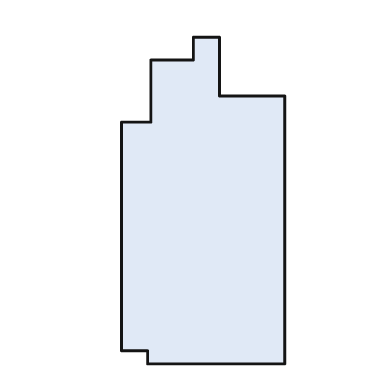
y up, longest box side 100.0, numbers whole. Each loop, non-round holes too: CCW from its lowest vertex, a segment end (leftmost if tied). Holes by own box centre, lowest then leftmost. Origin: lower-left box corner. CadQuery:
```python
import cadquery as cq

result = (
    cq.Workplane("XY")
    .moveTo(8.0, 0.0)
    .lineTo(50.0, 0.0)
    .lineTo(50.0, 82.0)
    .lineTo(30.0, 82.0)
    .lineTo(30.0, 100.0)
    .lineTo(22.0, 100.0)
    .lineTo(22.0, 93.0)
    .lineTo(9.0, 93.0)
    .lineTo(9.0, 74.0)
    .lineTo(0.0, 74.0)
    .lineTo(0.0, 4.0)
    .lineTo(8.0, 4.0)
    .close()
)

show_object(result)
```